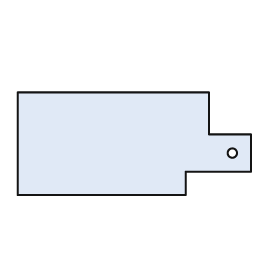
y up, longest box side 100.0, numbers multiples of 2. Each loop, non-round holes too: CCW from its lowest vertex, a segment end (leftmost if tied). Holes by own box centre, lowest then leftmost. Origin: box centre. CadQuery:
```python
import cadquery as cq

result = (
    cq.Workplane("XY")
    .moveTo(-50.0, -22.0)
    .lineTo(22.0, -22.0)
    .lineTo(22.0, -12.0)
    .lineTo(50.0, -12.0)
    .lineTo(50.0, 4.0)
    .lineTo(32.0, 4.0)
    .lineTo(32.0, 22.0)
    .lineTo(-50.0, 22.0)
    .close()
    .moveTo(42.0, -4.0)
    .circle(2.0)
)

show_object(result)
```